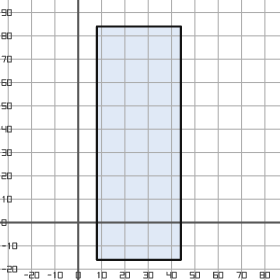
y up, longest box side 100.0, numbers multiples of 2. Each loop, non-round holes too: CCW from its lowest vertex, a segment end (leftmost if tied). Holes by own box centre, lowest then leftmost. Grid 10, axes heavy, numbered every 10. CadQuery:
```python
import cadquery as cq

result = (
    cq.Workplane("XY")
    .moveTo(8.0, -16.0)
    .lineTo(44.0, -16.0)
    .lineTo(44.0, 84.0)
    .lineTo(8.0, 84.0)
    .close()
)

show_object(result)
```